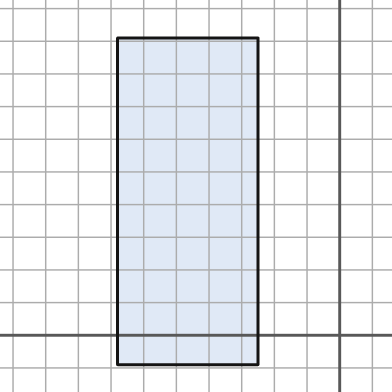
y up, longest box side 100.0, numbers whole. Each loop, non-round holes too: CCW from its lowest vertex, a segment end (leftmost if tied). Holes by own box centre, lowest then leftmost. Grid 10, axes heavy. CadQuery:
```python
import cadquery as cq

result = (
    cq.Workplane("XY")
    .moveTo(-68.0, -9.0)
    .lineTo(-25.0, -9.0)
    .lineTo(-25.0, 91.0)
    .lineTo(-68.0, 91.0)
    .close()
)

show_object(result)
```